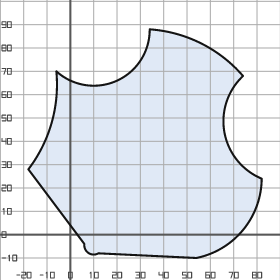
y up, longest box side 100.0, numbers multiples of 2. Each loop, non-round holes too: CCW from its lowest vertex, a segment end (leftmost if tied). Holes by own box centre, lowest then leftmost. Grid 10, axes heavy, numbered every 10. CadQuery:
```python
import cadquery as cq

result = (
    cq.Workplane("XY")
    .moveTo(54.0, -10.0)
    .threePointArc((74.0, 2.0), (82.0, 24.0))
    .threePointArc((66.0, 44.0), (74.0, 68.0))
    .threePointArc((56.0, 82.0), (34.0, 88.0))
    .threePointArc((20.0, 66.0), (-6.0, 70.0))
    .threePointArc((-8.0, 48.0), (-18.0, 28.0))
    .lineTo(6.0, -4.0)
    .threePointArc((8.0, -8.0), (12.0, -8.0))
    .close()
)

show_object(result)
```